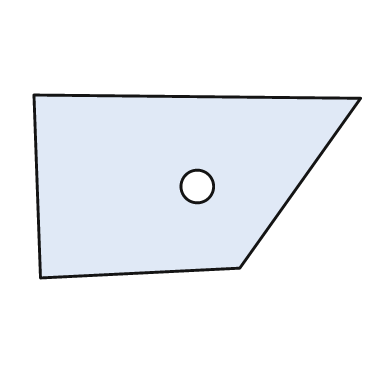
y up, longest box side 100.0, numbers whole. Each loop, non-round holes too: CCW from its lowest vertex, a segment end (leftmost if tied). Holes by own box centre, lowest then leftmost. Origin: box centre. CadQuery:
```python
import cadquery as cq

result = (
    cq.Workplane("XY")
    .moveTo(-48.0, -28.0)
    .lineTo(13.0, -25.0)
    .lineTo(50.0, 27.0)
    .lineTo(-50.0, 28.0)
    .close()
    .moveTo(0.0, 0.0)
    .circle(5.0)
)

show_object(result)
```